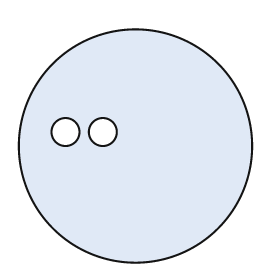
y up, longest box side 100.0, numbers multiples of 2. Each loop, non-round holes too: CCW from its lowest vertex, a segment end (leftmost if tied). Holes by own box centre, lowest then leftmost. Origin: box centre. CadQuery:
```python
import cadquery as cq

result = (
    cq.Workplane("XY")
    .moveTo(0.0, 0.0)
    .circle(50.0)
    .moveTo(-30.0, 6.0)
    .circle(6.0)
    .moveTo(-14.0, 6.0)
    .circle(6.0)
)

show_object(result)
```